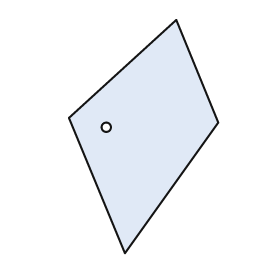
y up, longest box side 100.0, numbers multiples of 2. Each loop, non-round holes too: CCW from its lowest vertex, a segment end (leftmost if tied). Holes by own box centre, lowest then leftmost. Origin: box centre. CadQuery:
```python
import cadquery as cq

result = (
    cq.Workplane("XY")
    .moveTo(-8.0, -50.0)
    .lineTo(32.0, 6.0)
    .lineTo(14.0, 50.0)
    .lineTo(-32.0, 8.0)
    .close()
    .moveTo(-16.0, 4.0)
    .circle(2.0)
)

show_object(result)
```